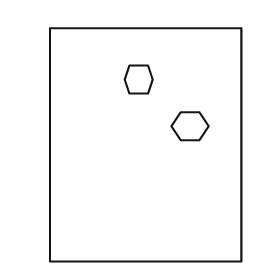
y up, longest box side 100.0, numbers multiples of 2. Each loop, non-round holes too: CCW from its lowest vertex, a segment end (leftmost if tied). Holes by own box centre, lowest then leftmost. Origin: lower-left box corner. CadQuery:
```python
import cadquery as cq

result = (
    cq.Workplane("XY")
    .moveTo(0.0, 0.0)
    .lineTo(82.0, 0.0)
    .lineTo(82.0, 100.0)
    .lineTo(0.0, 100.0)
    .close()
    .moveTo(56.0, 52.0)
    .lineTo(64.0, 52.0)
    .lineTo(68.0, 58.0)
    .lineTo(64.0, 64.0)
    .lineTo(56.0, 64.0)
    .lineTo(52.0, 58.0)
    .close()
    .moveTo(34.0, 72.0)
    .lineTo(42.0, 72.0)
    .lineTo(44.0, 78.0)
    .lineTo(42.0, 84.0)
    .lineTo(34.0, 84.0)
    .lineTo(32.0, 78.0)
    .close()
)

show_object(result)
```